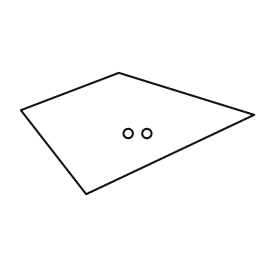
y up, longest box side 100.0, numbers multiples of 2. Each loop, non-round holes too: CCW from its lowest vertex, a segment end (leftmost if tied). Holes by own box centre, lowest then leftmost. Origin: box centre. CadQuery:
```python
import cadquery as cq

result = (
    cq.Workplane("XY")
    .moveTo(-22.0, -26.0)
    .lineTo(50.0, 8.0)
    .lineTo(-8.0, 26.0)
    .lineTo(-50.0, 10.0)
    .close()
    .moveTo(-4.0, 0.0)
    .circle(2.0)
    .moveTo(4.0, 0.0)
    .circle(2.0)
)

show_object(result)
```